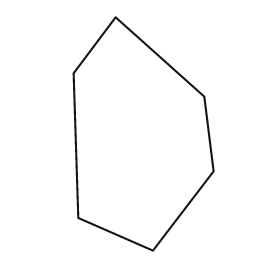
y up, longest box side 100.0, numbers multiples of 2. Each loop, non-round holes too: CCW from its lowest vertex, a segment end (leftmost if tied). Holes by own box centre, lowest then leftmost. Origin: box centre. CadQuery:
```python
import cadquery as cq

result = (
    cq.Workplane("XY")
    .moveTo(4.0, -50.0)
    .lineTo(30.0, -16.0)
    .lineTo(26.0, 16.0)
    .lineTo(-12.0, 50.0)
    .lineTo(-30.0, 26.0)
    .lineTo(-28.0, -36.0)
    .close()
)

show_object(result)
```